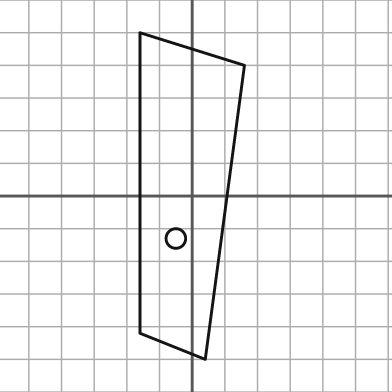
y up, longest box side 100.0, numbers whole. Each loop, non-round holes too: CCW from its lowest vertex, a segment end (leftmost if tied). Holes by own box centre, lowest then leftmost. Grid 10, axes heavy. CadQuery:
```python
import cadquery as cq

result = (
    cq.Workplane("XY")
    .moveTo(4.0, -50.0)
    .lineTo(16.0, 40.0)
    .lineTo(-16.0, 50.0)
    .lineTo(-16.0, -42.0)
    .close()
    .moveTo(-5.0, -13.0)
    .circle(3.0)
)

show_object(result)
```